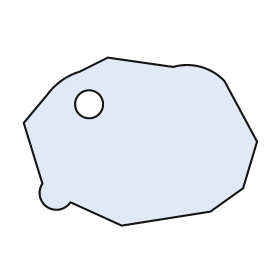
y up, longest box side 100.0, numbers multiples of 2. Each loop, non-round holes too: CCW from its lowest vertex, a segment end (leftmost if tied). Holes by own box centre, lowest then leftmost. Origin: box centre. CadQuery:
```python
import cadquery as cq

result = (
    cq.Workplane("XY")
    .moveTo(-8.0, -36.0)
    .lineTo(30.0, -30.0)
    .lineTo(44.0, -20.0)
    .lineTo(50.0, 0.0)
    .lineTo(36.0, 26.0)
    .threePointArc((26.0, 32.0), (14.0, 32.0))
    .lineTo(-14.0, 36.0)
    .lineTo(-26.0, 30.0)
    .threePointArc((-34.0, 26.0), (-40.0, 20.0))
    .lineTo(-50.0, 8.0)
    .lineTo(-42.0, -18.0)
    .threePointArc((-40.0, -28.0), (-30.0, -26.0))
    .close()
    .moveTo(-22.0, 16.0)
    .circle(6.0)
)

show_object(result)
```